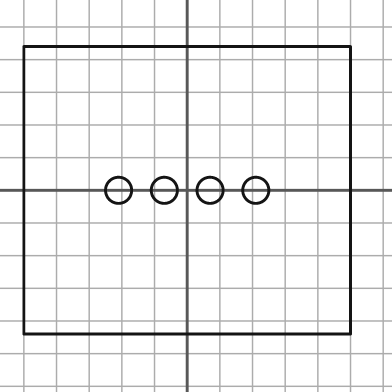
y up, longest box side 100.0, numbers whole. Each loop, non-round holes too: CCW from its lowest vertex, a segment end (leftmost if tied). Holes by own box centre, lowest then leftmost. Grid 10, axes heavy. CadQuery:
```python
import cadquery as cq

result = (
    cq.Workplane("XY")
    .moveTo(-50.0, -44.0)
    .lineTo(50.0, -44.0)
    .lineTo(50.0, 44.0)
    .lineTo(-50.0, 44.0)
    .close()
    .moveTo(-21.0, 0.0)
    .circle(4.0)
    .moveTo(-7.0, 0.0)
    .circle(4.0)
    .moveTo(7.0, 0.0)
    .circle(4.0)
    .moveTo(21.0, 0.0)
    .circle(4.0)
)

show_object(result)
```